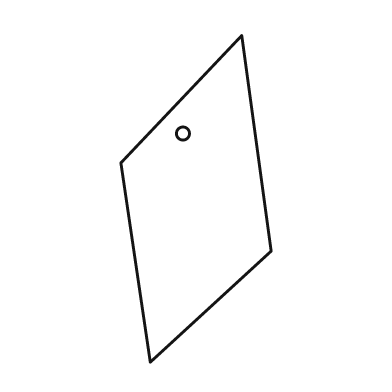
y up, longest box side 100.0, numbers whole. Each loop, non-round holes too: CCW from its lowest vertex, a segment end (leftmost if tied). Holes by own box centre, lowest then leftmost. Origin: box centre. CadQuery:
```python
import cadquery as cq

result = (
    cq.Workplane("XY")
    .moveTo(-14.0, -50.0)
    .lineTo(23.0, -16.0)
    .lineTo(14.0, 50.0)
    .lineTo(-23.0, 11.0)
    .close()
    .moveTo(-4.0, 20.0)
    .circle(2.0)
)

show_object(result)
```